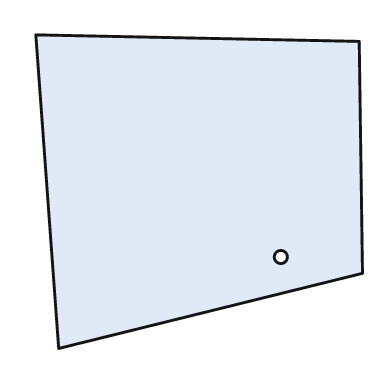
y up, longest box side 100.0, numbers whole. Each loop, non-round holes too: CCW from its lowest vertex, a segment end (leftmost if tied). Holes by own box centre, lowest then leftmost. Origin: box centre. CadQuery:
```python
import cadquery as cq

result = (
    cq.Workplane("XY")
    .moveTo(-43.0, -48.0)
    .lineTo(50.0, -25.0)
    .lineTo(49.0, 46.0)
    .lineTo(-50.0, 48.0)
    .close()
    .moveTo(25.0, -20.0)
    .circle(2.0)
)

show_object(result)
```